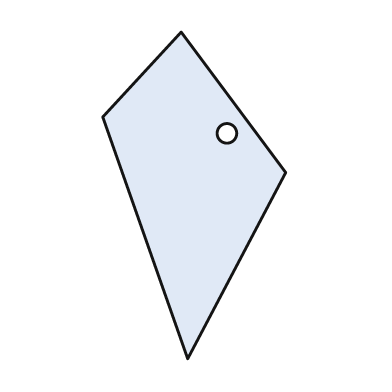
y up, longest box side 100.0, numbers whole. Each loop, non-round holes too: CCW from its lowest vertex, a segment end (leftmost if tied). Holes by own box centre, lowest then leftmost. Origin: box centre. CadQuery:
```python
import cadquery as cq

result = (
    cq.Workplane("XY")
    .moveTo(-2.0, -50.0)
    .lineTo(28.0, 7.0)
    .lineTo(-4.0, 50.0)
    .lineTo(-28.0, 24.0)
    .close()
    .moveTo(10.0, 19.0)
    .circle(3.0)
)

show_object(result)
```